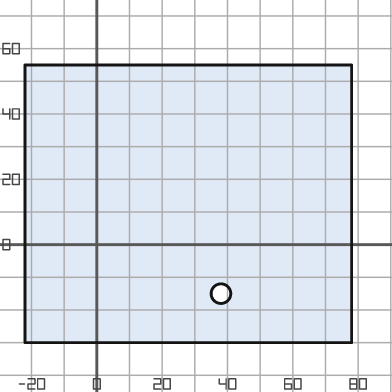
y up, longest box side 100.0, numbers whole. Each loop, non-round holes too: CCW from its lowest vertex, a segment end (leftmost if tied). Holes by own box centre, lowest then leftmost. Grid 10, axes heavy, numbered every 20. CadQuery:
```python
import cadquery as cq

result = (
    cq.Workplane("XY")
    .moveTo(-22.0, -30.0)
    .lineTo(78.0, -30.0)
    .lineTo(78.0, 55.0)
    .lineTo(-22.0, 55.0)
    .close()
    .moveTo(38.0, -15.0)
    .circle(3.0)
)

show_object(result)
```